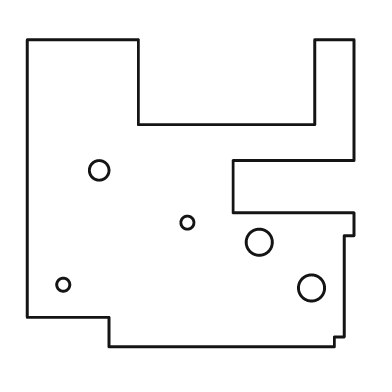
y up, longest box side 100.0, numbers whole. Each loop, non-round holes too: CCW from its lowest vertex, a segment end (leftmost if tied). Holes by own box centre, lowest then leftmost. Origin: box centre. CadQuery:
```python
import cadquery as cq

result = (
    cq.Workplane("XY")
    .moveTo(-25.0, -47.0)
    .lineTo(44.0, -47.0)
    .lineTo(44.0, -44.0)
    .lineTo(47.0, -44.0)
    .lineTo(47.0, -13.0)
    .lineTo(50.0, -13.0)
    .lineTo(50.0, -6.0)
    .lineTo(13.0, -6.0)
    .lineTo(13.0, 10.0)
    .lineTo(50.0, 10.0)
    .lineTo(50.0, 47.0)
    .lineTo(38.0, 47.0)
    .lineTo(38.0, 21.0)
    .lineTo(-16.0, 21.0)
    .lineTo(-16.0, 47.0)
    .lineTo(-50.0, 47.0)
    .lineTo(-50.0, -38.0)
    .lineTo(-25.0, -38.0)
    .close()
    .moveTo(37.0, -29.0)
    .circle(4.0)
    .moveTo(-39.0, -28.0)
    .circle(2.0)
    .moveTo(21.0, -15.0)
    .circle(4.0)
    .moveTo(-1.0, -9.0)
    .circle(2.0)
    .moveTo(-28.0, 7.0)
    .circle(3.0)
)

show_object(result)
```